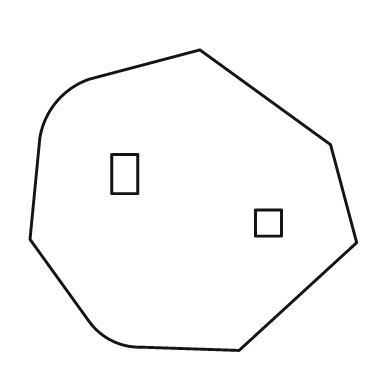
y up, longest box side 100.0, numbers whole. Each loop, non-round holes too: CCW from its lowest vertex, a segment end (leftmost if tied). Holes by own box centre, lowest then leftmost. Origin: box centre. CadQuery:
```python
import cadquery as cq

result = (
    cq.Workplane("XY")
    .moveTo(14.0, -46.0)
    .lineTo(50.0, -13.0)
    .lineTo(42.0, 17.0)
    .lineTo(2.0, 46.0)
    .lineTo(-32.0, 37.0)
    .threePointArc((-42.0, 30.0), (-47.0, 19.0))
    .lineTo(-50.0, -12.0)
    .lineTo(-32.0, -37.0)
    .threePointArc((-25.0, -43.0), (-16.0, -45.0))
    .close()
    .moveTo(19.0, -11.0)
    .lineTo(27.0, -11.0)
    .lineTo(27.0, -3.0)
    .lineTo(19.0, -3.0)
    .close()
    .moveTo(-25.0, 2.0)
    .lineTo(-17.0, 2.0)
    .lineTo(-17.0, 14.0)
    .lineTo(-25.0, 14.0)
    .close()
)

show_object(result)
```